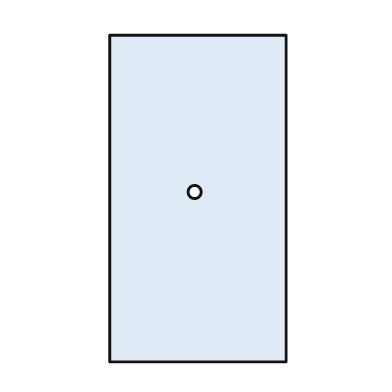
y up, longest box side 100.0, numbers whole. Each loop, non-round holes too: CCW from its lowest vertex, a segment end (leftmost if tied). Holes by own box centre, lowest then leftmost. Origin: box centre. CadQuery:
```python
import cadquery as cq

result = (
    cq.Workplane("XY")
    .moveTo(-27.0, -50.0)
    .lineTo(27.0, -50.0)
    .lineTo(27.0, 50.0)
    .lineTo(-27.0, 50.0)
    .close()
    .moveTo(-1.0, 2.0)
    .circle(2.0)
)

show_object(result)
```